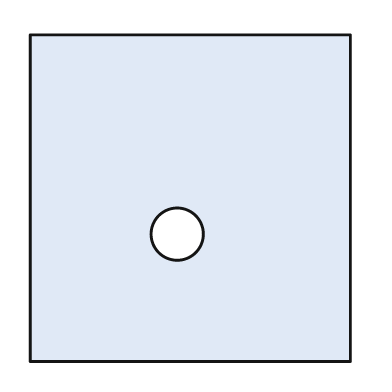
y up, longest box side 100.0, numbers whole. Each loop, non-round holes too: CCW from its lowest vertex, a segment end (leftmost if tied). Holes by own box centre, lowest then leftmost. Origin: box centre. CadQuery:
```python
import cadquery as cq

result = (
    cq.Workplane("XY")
    .moveTo(-49.0, -50.0)
    .lineTo(49.0, -50.0)
    .lineTo(49.0, 50.0)
    .lineTo(-49.0, 50.0)
    .close()
    .moveTo(-4.0, -11.0)
    .circle(8.0)
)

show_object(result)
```